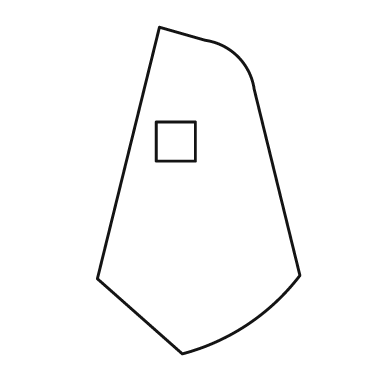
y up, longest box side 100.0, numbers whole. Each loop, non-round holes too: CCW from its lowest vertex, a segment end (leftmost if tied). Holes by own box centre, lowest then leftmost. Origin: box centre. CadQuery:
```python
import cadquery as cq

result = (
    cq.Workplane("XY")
    .moveTo(-5.0, -50.0)
    .threePointArc((15.0, -41.0), (31.0, -26.0))
    .lineTo(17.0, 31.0)
    .threePointArc((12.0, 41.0), (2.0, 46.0))
    .lineTo(-12.0, 50.0)
    .lineTo(-31.0, -27.0)
    .close()
    .moveTo(-13.0, 9.0)
    .lineTo(-1.0, 9.0)
    .lineTo(-1.0, 21.0)
    .lineTo(-13.0, 21.0)
    .close()
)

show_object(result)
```